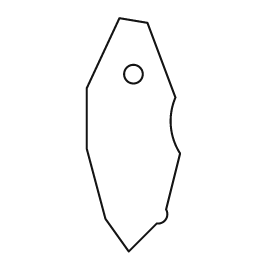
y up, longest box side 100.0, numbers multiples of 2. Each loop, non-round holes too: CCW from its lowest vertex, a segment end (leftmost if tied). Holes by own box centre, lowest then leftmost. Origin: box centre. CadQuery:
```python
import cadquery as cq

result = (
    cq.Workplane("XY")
    .moveTo(-2.0, -50.0)
    .lineTo(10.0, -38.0)
    .threePointArc((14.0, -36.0), (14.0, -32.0))
    .lineTo(20.0, -8.0)
    .threePointArc((16.0, 4.0), (18.0, 16.0))
    .lineTo(6.0, 48.0)
    .lineTo(-6.0, 50.0)
    .lineTo(-20.0, 20.0)
    .lineTo(-20.0, -6.0)
    .lineTo(-12.0, -36.0)
    .close()
    .moveTo(0.0, 26.0)
    .circle(4.0)
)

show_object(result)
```